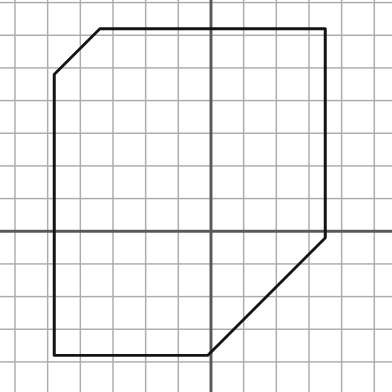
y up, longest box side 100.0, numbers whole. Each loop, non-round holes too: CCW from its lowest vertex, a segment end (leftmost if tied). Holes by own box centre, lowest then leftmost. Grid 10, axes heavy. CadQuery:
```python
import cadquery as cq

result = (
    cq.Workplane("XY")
    .moveTo(-48.0, -38.0)
    .lineTo(-1.0, -38.0)
    .lineTo(35.0, -2.0)
    .lineTo(35.0, 62.0)
    .lineTo(-34.0, 62.0)
    .lineTo(-48.0, 48.0)
    .close()
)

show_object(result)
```